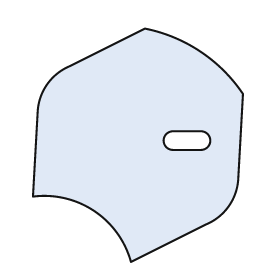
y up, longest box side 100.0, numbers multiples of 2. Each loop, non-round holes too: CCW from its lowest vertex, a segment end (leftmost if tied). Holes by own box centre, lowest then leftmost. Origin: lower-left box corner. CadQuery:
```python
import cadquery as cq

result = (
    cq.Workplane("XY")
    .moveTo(42.0, 0.0)
    .lineTo(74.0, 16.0)
    .threePointArc((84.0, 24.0), (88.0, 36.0))
    .lineTo(90.0, 72.0)
    .threePointArc((72.0, 90.0), (48.0, 100.0))
    .lineTo(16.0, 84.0)
    .threePointArc((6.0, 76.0), (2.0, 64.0))
    .lineTo(0.0, 28.0)
    .threePointArc((26.0, 22.0), (42.0, 0.0))
    .close()
    .moveTo(60.0, 48.0)
    .lineTo(72.0, 48.0)
    .threePointArc((76.0, 52.0), (72.0, 56.0))
    .lineTo(60.0, 56.0)
    .threePointArc((56.0, 52.0), (60.0, 48.0))
    .close()
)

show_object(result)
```